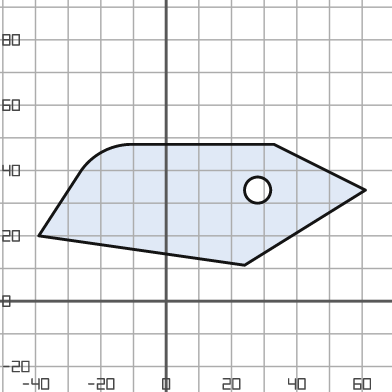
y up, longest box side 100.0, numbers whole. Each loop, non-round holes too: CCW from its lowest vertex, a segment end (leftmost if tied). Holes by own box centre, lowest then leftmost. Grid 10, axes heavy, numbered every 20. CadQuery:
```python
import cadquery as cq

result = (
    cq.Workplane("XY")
    .moveTo(24.0, 11.0)
    .lineTo(61.0, 34.0)
    .lineTo(33.0, 48.0)
    .lineTo(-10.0, 48.0)
    .threePointArc((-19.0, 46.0), (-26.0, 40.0))
    .lineTo(-39.0, 20.0)
    .close()
    .moveTo(28.0, 34.0)
    .circle(4.0)
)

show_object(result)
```